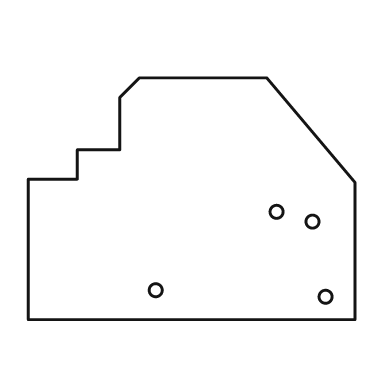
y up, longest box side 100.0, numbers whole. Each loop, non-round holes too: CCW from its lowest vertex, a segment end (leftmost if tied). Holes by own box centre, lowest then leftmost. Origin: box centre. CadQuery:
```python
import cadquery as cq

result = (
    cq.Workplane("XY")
    .moveTo(-50.0, -37.0)
    .lineTo(50.0, -37.0)
    .lineTo(50.0, 5.0)
    .lineTo(23.0, 37.0)
    .lineTo(-16.0, 37.0)
    .lineTo(-22.0, 31.0)
    .lineTo(-22.0, 15.0)
    .lineTo(-35.0, 15.0)
    .lineTo(-35.0, 6.0)
    .lineTo(-50.0, 6.0)
    .close()
    .moveTo(41.0, -30.0)
    .circle(2.0)
    .moveTo(-11.0, -28.0)
    .circle(2.0)
    .moveTo(37.0, -7.0)
    .circle(2.0)
    .moveTo(26.0, -4.0)
    .circle(2.0)
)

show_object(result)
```